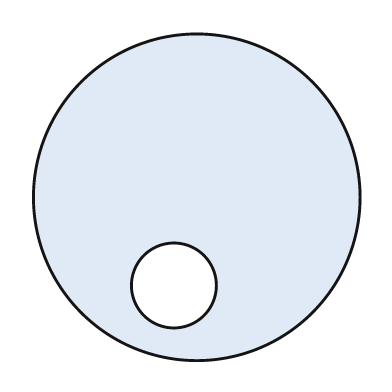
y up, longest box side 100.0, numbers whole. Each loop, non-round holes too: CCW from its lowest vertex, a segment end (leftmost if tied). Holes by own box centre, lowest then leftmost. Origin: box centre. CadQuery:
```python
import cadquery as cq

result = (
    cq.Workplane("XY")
    .moveTo(0.0, 0.0)
    .circle(50.0)
    .moveTo(-7.0, -27.0)
    .circle(13.0)
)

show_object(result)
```